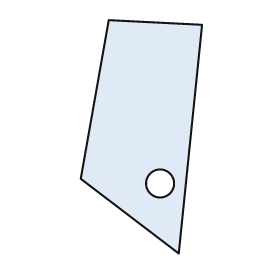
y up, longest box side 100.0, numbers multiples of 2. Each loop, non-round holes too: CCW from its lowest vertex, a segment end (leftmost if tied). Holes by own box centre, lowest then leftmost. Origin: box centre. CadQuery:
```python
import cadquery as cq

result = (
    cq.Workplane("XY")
    .moveTo(16.0, -50.0)
    .lineTo(26.0, 48.0)
    .lineTo(-14.0, 50.0)
    .lineTo(-26.0, -18.0)
    .close()
    .moveTo(8.0, -20.0)
    .circle(6.0)
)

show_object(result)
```